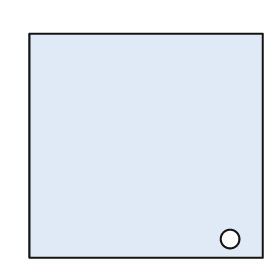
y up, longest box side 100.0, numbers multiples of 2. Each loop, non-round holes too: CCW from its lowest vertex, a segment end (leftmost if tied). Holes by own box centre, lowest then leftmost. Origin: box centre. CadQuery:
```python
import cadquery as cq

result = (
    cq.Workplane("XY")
    .moveTo(-50.0, -48.0)
    .lineTo(50.0, -48.0)
    .lineTo(50.0, 48.0)
    .lineTo(-50.0, 48.0)
    .close()
    .moveTo(36.0, -40.0)
    .circle(4.0)
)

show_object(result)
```